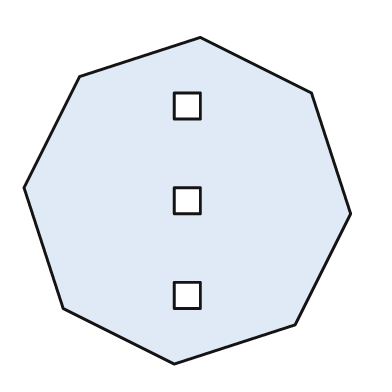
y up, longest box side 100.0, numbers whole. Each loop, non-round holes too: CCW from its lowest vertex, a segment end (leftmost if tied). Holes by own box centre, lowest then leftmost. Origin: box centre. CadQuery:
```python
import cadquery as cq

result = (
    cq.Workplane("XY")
    .moveTo(-4.0, -50.0)
    .lineTo(33.0, -38.0)
    .lineTo(50.0, -4.0)
    .lineTo(38.0, 33.0)
    .lineTo(4.0, 50.0)
    .lineTo(-33.0, 38.0)
    .lineTo(-50.0, 4.0)
    .lineTo(-38.0, -33.0)
    .close()
    .moveTo(-4.0, -33.0)
    .lineTo(4.0, -33.0)
    .lineTo(4.0, -25.0)
    .lineTo(-4.0, -25.0)
    .close()
    .moveTo(-4.0, -4.0)
    .lineTo(4.0, -4.0)
    .lineTo(4.0, 4.0)
    .lineTo(-4.0, 4.0)
    .close()
    .moveTo(-4.0, 25.0)
    .lineTo(4.0, 25.0)
    .lineTo(4.0, 33.0)
    .lineTo(-4.0, 33.0)
    .close()
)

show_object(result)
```